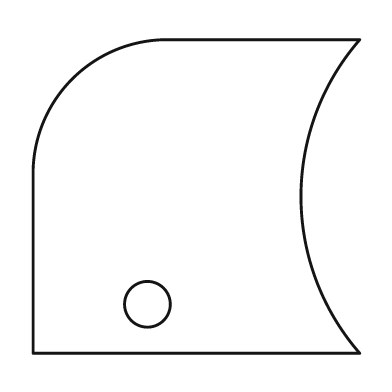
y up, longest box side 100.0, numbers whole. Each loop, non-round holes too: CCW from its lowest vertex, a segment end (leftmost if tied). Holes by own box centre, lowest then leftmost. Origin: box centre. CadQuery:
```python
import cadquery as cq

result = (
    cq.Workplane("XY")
    .moveTo(-50.0, -48.0)
    .lineTo(50.0, -48.0)
    .threePointArc((32.0, 0.0), (50.0, 48.0))
    .lineTo(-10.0, 48.0)
    .threePointArc((-38.0, 36.0), (-50.0, 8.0))
    .close()
    .moveTo(-15.0, -33.0)
    .circle(7.0)
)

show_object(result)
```